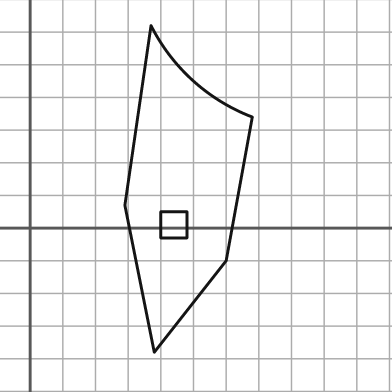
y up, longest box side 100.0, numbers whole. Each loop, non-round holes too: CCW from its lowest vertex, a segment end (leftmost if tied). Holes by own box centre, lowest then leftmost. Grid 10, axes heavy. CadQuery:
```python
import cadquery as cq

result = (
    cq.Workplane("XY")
    .moveTo(38.0, -38.0)
    .lineTo(60.0, -10.0)
    .lineTo(68.0, 34.0)
    .threePointArc((50.0, 45.0), (37.0, 62.0))
    .lineTo(29.0, 7.0)
    .close()
    .moveTo(40.0, -3.0)
    .lineTo(48.0, -3.0)
    .lineTo(48.0, 5.0)
    .lineTo(40.0, 5.0)
    .close()
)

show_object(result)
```